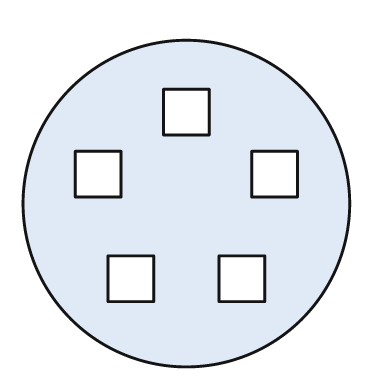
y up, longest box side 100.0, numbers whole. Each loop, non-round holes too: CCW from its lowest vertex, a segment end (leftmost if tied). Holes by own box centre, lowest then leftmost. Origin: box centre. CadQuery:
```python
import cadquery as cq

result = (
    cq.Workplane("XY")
    .moveTo(0.0, 0.0)
    .circle(50.0)
    .moveTo(-24.0, -30.0)
    .lineTo(-10.0, -30.0)
    .lineTo(-10.0, -16.0)
    .lineTo(-24.0, -16.0)
    .close()
    .moveTo(10.0, -30.0)
    .lineTo(24.0, -30.0)
    .lineTo(24.0, -16.0)
    .lineTo(10.0, -16.0)
    .close()
    .moveTo(-34.0, 2.0)
    .lineTo(-20.0, 2.0)
    .lineTo(-20.0, 16.0)
    .lineTo(-34.0, 16.0)
    .close()
    .moveTo(20.0, 2.0)
    .lineTo(34.0, 2.0)
    .lineTo(34.0, 16.0)
    .lineTo(20.0, 16.0)
    .close()
    .moveTo(-7.0, 21.0)
    .lineTo(7.0, 21.0)
    .lineTo(7.0, 35.0)
    .lineTo(-7.0, 35.0)
    .close()
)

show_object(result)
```